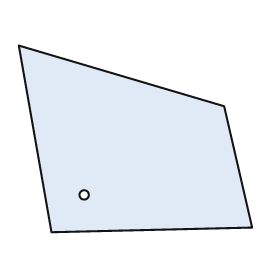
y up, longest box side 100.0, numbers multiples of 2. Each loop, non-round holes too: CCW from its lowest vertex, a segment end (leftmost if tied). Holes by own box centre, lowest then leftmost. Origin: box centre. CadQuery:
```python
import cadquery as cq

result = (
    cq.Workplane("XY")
    .moveTo(-36.0, -40.0)
    .lineTo(50.0, -38.0)
    .lineTo(38.0, 14.0)
    .lineTo(-50.0, 40.0)
    .close()
    .moveTo(-22.0, -24.0)
    .circle(2.0)
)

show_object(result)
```